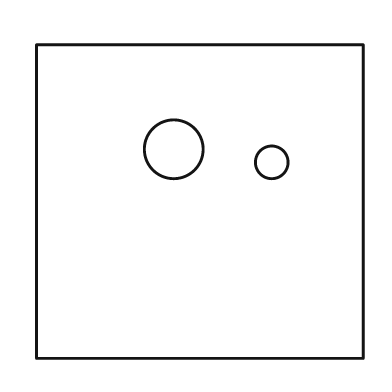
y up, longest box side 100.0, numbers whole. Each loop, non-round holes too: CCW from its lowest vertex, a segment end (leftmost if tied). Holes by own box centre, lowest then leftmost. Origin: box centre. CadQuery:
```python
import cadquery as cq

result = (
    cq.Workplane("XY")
    .moveTo(-50.0, -48.0)
    .lineTo(50.0, -48.0)
    .lineTo(50.0, 48.0)
    .lineTo(-50.0, 48.0)
    .close()
    .moveTo(22.0, 12.0)
    .circle(5.0)
    .moveTo(-8.0, 16.0)
    .circle(9.0)
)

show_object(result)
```